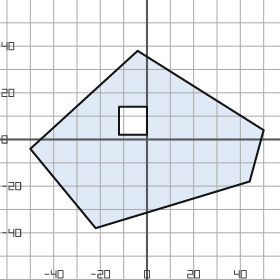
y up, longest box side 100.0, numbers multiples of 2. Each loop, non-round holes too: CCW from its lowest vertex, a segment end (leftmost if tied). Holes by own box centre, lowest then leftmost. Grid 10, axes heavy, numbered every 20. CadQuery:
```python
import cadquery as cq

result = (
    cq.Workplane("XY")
    .moveTo(-22.0, -38.0)
    .lineTo(44.0, -18.0)
    .lineTo(50.0, 4.0)
    .lineTo(-4.0, 38.0)
    .lineTo(-50.0, -4.0)
    .close()
    .moveTo(-12.0, 2.0)
    .lineTo(0.0, 2.0)
    .lineTo(0.0, 14.0)
    .lineTo(-12.0, 14.0)
    .close()
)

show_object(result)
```